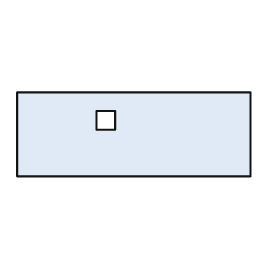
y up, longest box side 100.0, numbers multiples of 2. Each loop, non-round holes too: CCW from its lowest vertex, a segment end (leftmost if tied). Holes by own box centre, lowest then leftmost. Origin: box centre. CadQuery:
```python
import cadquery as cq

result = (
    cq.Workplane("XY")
    .moveTo(-50.0, -18.0)
    .lineTo(50.0, -18.0)
    .lineTo(50.0, 18.0)
    .lineTo(-50.0, 18.0)
    .close()
    .moveTo(-16.0, 2.0)
    .lineTo(-8.0, 2.0)
    .lineTo(-8.0, 10.0)
    .lineTo(-16.0, 10.0)
    .close()
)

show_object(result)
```